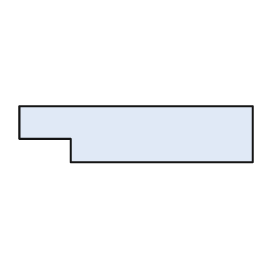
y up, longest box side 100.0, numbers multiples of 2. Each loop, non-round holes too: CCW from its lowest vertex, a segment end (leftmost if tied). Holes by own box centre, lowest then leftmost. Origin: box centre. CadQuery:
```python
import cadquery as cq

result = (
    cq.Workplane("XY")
    .moveTo(-28.0, -12.0)
    .lineTo(50.0, -12.0)
    .lineTo(50.0, 12.0)
    .lineTo(-50.0, 12.0)
    .lineTo(-50.0, -2.0)
    .lineTo(-28.0, -2.0)
    .close()
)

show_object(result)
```